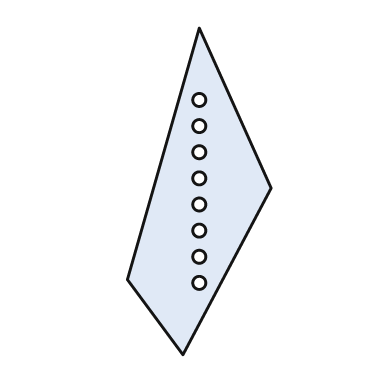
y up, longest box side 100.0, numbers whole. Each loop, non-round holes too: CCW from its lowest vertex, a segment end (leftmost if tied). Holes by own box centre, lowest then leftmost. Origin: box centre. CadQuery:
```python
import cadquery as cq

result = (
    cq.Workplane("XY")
    .moveTo(-5.0, -50.0)
    .lineTo(22.0, 1.0)
    .lineTo(0.0, 50.0)
    .lineTo(-22.0, -27.0)
    .close()
    .moveTo(0.0, -28.0)
    .circle(2.0)
    .moveTo(0.0, -20.0)
    .circle(2.0)
    .moveTo(0.0, -12.0)
    .circle(2.0)
    .moveTo(0.0, -4.0)
    .circle(2.0)
    .moveTo(0.0, 4.0)
    .circle(2.0)
    .moveTo(0.0, 12.0)
    .circle(2.0)
    .moveTo(0.0, 20.0)
    .circle(2.0)
    .moveTo(0.0, 28.0)
    .circle(2.0)
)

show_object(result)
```